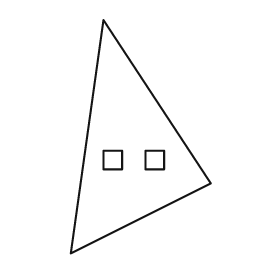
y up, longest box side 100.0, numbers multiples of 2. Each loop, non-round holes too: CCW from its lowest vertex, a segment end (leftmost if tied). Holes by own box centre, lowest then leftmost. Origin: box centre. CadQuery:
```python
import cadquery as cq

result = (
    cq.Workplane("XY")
    .moveTo(-30.0, -50.0)
    .lineTo(30.0, -20.0)
    .lineTo(-16.0, 50.0)
    .close()
    .moveTo(-16.0, -14.0)
    .lineTo(-8.0, -14.0)
    .lineTo(-8.0, -6.0)
    .lineTo(-16.0, -6.0)
    .close()
    .moveTo(2.0, -14.0)
    .lineTo(10.0, -14.0)
    .lineTo(10.0, -6.0)
    .lineTo(2.0, -6.0)
    .close()
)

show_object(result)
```